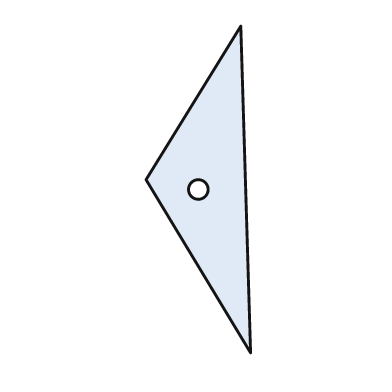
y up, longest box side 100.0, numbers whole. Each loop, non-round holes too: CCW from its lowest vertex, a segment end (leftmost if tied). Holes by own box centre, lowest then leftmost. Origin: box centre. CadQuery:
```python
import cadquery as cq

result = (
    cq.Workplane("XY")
    .moveTo(16.0, -50.0)
    .lineTo(13.0, 50.0)
    .lineTo(-16.0, 3.0)
    .close()
    .moveTo(0.0, 0.0)
    .circle(3.0)
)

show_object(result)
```